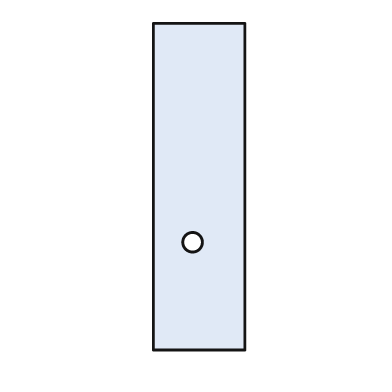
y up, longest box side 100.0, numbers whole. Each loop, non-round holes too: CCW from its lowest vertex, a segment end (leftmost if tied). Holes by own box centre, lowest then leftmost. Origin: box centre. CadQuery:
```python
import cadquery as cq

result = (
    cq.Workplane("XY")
    .moveTo(-14.0, -50.0)
    .lineTo(14.0, -50.0)
    .lineTo(14.0, 50.0)
    .lineTo(-14.0, 50.0)
    .close()
    .moveTo(-2.0, -17.0)
    .circle(3.0)
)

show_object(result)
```